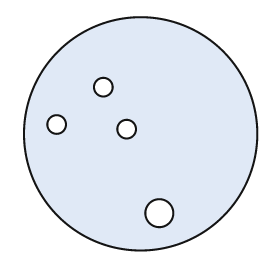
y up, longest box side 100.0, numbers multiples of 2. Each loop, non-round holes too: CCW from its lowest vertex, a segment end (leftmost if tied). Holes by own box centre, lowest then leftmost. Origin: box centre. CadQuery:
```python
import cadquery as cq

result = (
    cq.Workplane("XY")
    .moveTo(0.0, 0.0)
    .circle(50.0)
    .moveTo(8.0, -34.0)
    .circle(6.0)
    .moveTo(-6.0, 2.0)
    .circle(4.0)
    .moveTo(-36.0, 4.0)
    .circle(4.0)
    .moveTo(-16.0, 20.0)
    .circle(4.0)
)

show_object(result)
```